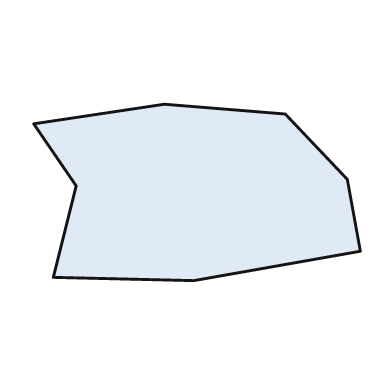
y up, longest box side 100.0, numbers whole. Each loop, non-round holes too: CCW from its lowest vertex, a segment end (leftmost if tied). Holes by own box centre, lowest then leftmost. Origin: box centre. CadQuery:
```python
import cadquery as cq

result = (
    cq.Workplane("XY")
    .moveTo(-1.0, -27.0)
    .lineTo(50.0, -18.0)
    .lineTo(46.0, 4.0)
    .lineTo(27.0, 24.0)
    .lineTo(-10.0, 27.0)
    .lineTo(-50.0, 21.0)
    .lineTo(-37.0, 2.0)
    .lineTo(-44.0, -26.0)
    .close()
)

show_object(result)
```